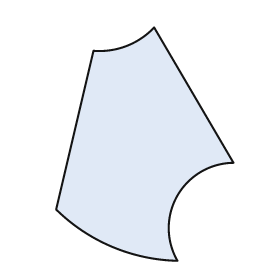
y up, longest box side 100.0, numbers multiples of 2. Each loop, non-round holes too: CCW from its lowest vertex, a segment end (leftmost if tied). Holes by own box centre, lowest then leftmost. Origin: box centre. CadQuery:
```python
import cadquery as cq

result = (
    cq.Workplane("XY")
    .moveTo(14.0, -50.0)
    .threePointArc((14.0, -22.0), (38.0, -8.0))
    .lineTo(4.0, 50.0)
    .threePointArc((-8.0, 42.0), (-22.0, 40.0))
    .lineTo(-38.0, -28.0)
    .threePointArc((-14.0, -44.0), (14.0, -50.0))
    .close()
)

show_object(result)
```